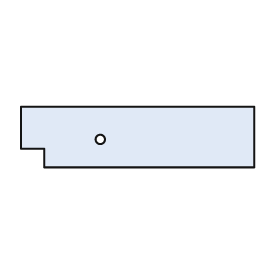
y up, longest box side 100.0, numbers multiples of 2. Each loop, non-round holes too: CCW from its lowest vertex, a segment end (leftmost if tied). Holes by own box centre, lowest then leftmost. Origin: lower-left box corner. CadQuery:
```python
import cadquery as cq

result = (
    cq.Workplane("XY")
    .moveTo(10.0, 0.0)
    .lineTo(100.0, 0.0)
    .lineTo(100.0, 26.0)
    .lineTo(0.0, 26.0)
    .lineTo(0.0, 8.0)
    .lineTo(10.0, 8.0)
    .close()
    .moveTo(34.0, 12.0)
    .circle(2.0)
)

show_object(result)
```